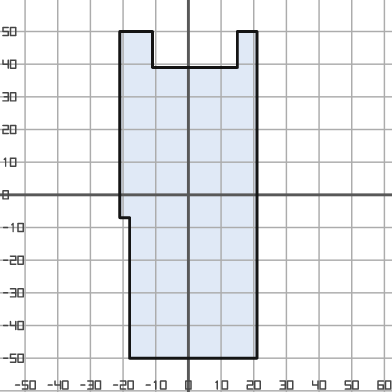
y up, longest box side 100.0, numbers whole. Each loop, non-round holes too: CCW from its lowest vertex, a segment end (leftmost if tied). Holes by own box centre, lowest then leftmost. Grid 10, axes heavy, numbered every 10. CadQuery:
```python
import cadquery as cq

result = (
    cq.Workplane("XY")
    .moveTo(-18.0, -50.0)
    .lineTo(21.0, -50.0)
    .lineTo(21.0, 50.0)
    .lineTo(15.0, 50.0)
    .lineTo(15.0, 39.0)
    .lineTo(-11.0, 39.0)
    .lineTo(-11.0, 50.0)
    .lineTo(-21.0, 50.0)
    .lineTo(-21.0, -7.0)
    .lineTo(-18.0, -7.0)
    .close()
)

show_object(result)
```